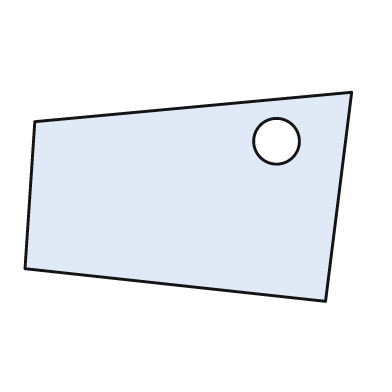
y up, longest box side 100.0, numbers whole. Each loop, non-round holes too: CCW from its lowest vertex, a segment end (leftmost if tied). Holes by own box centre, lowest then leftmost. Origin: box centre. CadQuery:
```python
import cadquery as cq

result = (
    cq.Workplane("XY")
    .moveTo(42.0, -32.0)
    .lineTo(50.0, 32.0)
    .lineTo(-47.0, 23.0)
    .lineTo(-50.0, -22.0)
    .close()
    .moveTo(27.0, 17.0)
    .circle(7.0)
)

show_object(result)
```